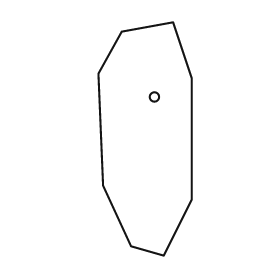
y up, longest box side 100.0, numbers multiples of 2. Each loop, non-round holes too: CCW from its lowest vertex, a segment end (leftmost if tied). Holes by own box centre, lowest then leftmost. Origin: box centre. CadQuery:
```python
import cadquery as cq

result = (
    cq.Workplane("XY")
    .moveTo(8.0, -50.0)
    .lineTo(20.0, -26.0)
    .lineTo(20.0, 26.0)
    .lineTo(12.0, 50.0)
    .lineTo(-10.0, 46.0)
    .lineTo(-20.0, 28.0)
    .lineTo(-18.0, -20.0)
    .lineTo(-6.0, -46.0)
    .close()
    .moveTo(4.0, 18.0)
    .circle(2.0)
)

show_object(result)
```